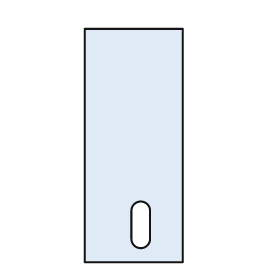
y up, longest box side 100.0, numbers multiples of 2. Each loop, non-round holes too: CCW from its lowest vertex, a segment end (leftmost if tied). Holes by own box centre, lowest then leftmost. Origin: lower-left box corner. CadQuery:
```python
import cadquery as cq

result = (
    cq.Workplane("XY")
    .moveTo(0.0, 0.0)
    .lineTo(42.0, 0.0)
    .lineTo(42.0, 100.0)
    .lineTo(0.0, 100.0)
    .close()
    .moveTo(20.0, 10.0)
    .threePointArc((24.0, 6.0), (28.0, 10.0))
    .lineTo(28.0, 22.0)
    .threePointArc((24.0, 26.0), (20.0, 22.0))
    .close()
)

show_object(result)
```